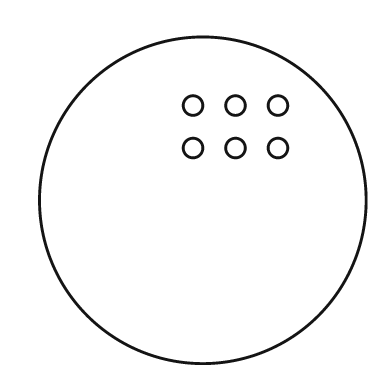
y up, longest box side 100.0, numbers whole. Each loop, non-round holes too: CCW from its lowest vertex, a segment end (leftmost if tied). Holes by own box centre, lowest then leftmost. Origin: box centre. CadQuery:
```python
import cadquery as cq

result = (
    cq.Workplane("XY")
    .moveTo(0.0, 0.0)
    .circle(50.0)
    .moveTo(-3.0, 16.0)
    .circle(3.0)
    .moveTo(10.0, 16.0)
    .circle(3.0)
    .moveTo(23.0, 16.0)
    .circle(3.0)
    .moveTo(-3.0, 29.0)
    .circle(3.0)
    .moveTo(10.0, 29.0)
    .circle(3.0)
    .moveTo(23.0, 29.0)
    .circle(3.0)
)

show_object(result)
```